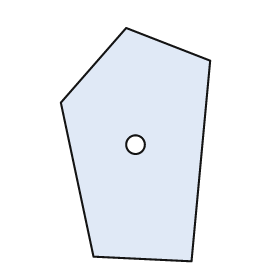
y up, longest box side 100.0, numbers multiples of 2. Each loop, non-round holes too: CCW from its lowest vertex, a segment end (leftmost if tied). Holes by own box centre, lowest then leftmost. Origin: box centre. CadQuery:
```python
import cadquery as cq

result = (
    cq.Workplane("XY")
    .moveTo(24.0, -50.0)
    .lineTo(32.0, 36.0)
    .lineTo(-4.0, 50.0)
    .lineTo(-32.0, 18.0)
    .lineTo(-18.0, -48.0)
    .close()
    .moveTo(0.0, 0.0)
    .circle(4.0)
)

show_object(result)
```